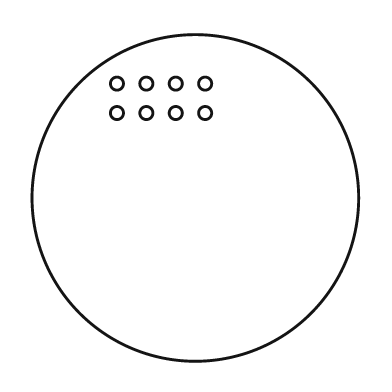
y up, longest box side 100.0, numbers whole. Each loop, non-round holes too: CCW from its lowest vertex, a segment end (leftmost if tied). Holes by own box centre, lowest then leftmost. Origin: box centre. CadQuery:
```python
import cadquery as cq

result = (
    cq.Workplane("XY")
    .moveTo(0.0, 0.0)
    .circle(50.0)
    .moveTo(-24.0, 26.0)
    .circle(2.0)
    .moveTo(-15.0, 26.0)
    .circle(2.0)
    .moveTo(-6.0, 26.0)
    .circle(2.0)
    .moveTo(3.0, 26.0)
    .circle(2.0)
    .moveTo(-24.0, 35.0)
    .circle(2.0)
    .moveTo(-15.0, 35.0)
    .circle(2.0)
    .moveTo(-6.0, 35.0)
    .circle(2.0)
    .moveTo(3.0, 35.0)
    .circle(2.0)
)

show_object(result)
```